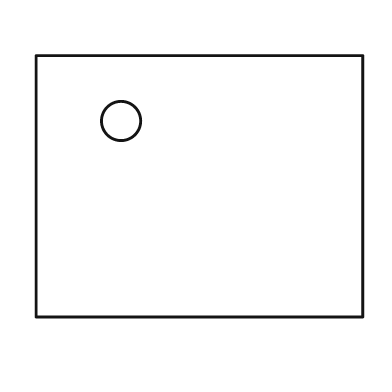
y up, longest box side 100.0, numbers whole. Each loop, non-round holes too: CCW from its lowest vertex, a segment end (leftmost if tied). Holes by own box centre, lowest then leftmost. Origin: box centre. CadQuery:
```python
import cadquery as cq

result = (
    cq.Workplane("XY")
    .moveTo(-50.0, -40.0)
    .lineTo(50.0, -40.0)
    .lineTo(50.0, 40.0)
    .lineTo(-50.0, 40.0)
    .close()
    .moveTo(-24.0, 20.0)
    .circle(6.0)
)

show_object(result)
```